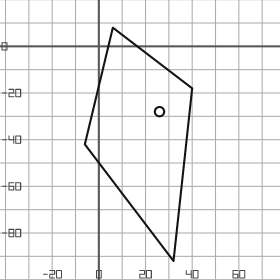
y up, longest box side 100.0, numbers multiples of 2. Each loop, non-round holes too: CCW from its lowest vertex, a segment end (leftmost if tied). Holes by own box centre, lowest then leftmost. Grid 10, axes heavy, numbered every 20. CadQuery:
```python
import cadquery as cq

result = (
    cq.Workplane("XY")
    .moveTo(32.0, -92.0)
    .lineTo(40.0, -18.0)
    .lineTo(6.0, 8.0)
    .lineTo(-6.0, -42.0)
    .close()
    .moveTo(26.0, -28.0)
    .circle(2.0)
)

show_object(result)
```